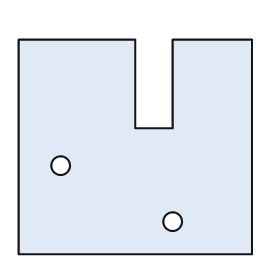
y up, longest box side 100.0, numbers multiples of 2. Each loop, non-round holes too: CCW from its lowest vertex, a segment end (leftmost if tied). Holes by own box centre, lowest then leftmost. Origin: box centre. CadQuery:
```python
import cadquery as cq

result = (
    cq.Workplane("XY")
    .moveTo(-50.0, -46.0)
    .lineTo(50.0, -46.0)
    .lineTo(50.0, 46.0)
    .lineTo(16.0, 46.0)
    .lineTo(16.0, 8.0)
    .lineTo(0.0, 8.0)
    .lineTo(0.0, 46.0)
    .lineTo(-50.0, 46.0)
    .close()
    .moveTo(16.0, -32.0)
    .circle(4.0)
    .moveTo(-32.0, -8.0)
    .circle(4.0)
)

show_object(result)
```